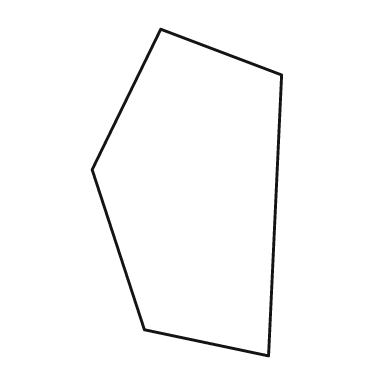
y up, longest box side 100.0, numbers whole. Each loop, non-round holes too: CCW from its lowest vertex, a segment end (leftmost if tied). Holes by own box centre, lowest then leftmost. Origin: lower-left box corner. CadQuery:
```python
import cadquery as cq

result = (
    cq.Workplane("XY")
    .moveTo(54.0, 0.0)
    .lineTo(58.0, 86.0)
    .lineTo(21.0, 100.0)
    .lineTo(0.0, 57.0)
    .lineTo(16.0, 8.0)
    .close()
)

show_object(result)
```